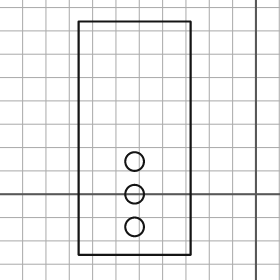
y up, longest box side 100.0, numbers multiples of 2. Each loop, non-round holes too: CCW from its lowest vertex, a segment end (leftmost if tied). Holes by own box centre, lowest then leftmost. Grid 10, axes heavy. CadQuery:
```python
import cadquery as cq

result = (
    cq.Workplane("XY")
    .moveTo(-76.0, -26.0)
    .lineTo(-28.0, -26.0)
    .lineTo(-28.0, 74.0)
    .lineTo(-76.0, 74.0)
    .close()
    .moveTo(-52.0, -14.0)
    .circle(4.0)
    .moveTo(-52.0, 0.0)
    .circle(4.0)
    .moveTo(-52.0, 14.0)
    .circle(4.0)
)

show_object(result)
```